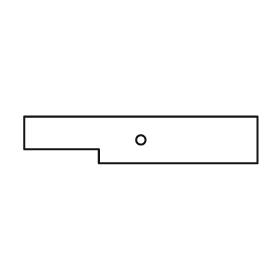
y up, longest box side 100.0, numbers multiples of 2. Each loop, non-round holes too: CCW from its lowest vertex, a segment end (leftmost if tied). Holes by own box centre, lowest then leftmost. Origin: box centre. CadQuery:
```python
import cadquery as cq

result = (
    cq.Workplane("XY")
    .moveTo(-18.0, -10.0)
    .lineTo(50.0, -10.0)
    .lineTo(50.0, 10.0)
    .lineTo(-50.0, 10.0)
    .lineTo(-50.0, -4.0)
    .lineTo(-18.0, -4.0)
    .close()
    .moveTo(0.0, 0.0)
    .circle(2.0)
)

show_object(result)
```